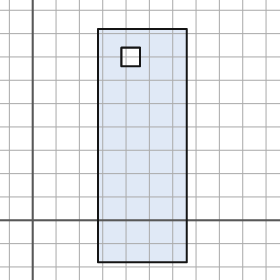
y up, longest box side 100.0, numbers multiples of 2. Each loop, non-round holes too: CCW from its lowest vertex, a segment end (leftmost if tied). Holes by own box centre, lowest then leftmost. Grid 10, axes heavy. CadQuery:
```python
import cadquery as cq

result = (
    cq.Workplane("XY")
    .moveTo(28.0, -18.0)
    .lineTo(66.0, -18.0)
    .lineTo(66.0, 82.0)
    .lineTo(28.0, 82.0)
    .close()
    .moveTo(38.0, 66.0)
    .lineTo(46.0, 66.0)
    .lineTo(46.0, 74.0)
    .lineTo(38.0, 74.0)
    .close()
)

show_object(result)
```